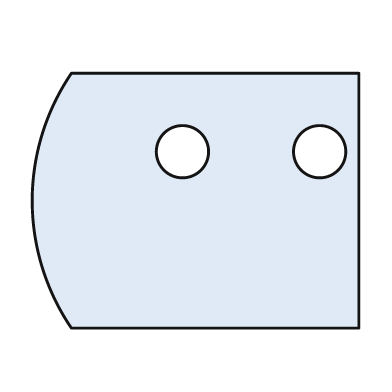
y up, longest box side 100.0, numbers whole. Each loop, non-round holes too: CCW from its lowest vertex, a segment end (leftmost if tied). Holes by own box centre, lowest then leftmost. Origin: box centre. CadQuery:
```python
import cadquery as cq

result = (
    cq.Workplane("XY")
    .moveTo(-38.0, -39.0)
    .lineTo(50.0, -39.0)
    .lineTo(50.0, 39.0)
    .lineTo(-38.0, 39.0)
    .threePointArc((-50.0, 0.0), (-38.0, -39.0))
    .close()
    .moveTo(-4.0, 15.0)
    .circle(8.0)
    .moveTo(38.0, 15.0)
    .circle(8.0)
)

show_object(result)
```